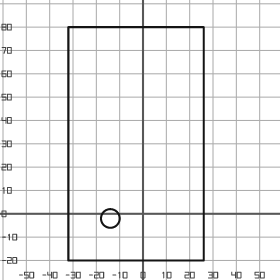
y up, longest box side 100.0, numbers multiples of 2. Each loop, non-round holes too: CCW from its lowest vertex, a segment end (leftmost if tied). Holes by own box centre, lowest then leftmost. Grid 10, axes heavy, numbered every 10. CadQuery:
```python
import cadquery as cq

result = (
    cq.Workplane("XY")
    .moveTo(-32.0, -20.0)
    .lineTo(26.0, -20.0)
    .lineTo(26.0, 80.0)
    .lineTo(-32.0, 80.0)
    .close()
    .moveTo(-14.0, -2.0)
    .circle(4.0)
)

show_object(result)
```